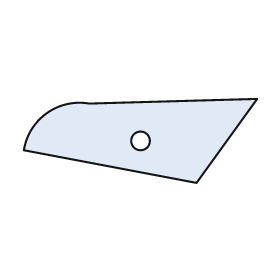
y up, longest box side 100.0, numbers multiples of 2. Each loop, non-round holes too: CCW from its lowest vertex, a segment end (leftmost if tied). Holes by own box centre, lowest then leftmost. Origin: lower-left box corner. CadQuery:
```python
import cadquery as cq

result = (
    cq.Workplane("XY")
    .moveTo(74.0, 0.0)
    .lineTo(100.0, 36.0)
    .lineTo(28.0, 34.0)
    .threePointArc((10.0, 30.0), (0.0, 14.0))
    .close()
    .moveTo(50.0, 18.0)
    .circle(4.0)
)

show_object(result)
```